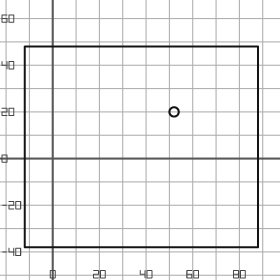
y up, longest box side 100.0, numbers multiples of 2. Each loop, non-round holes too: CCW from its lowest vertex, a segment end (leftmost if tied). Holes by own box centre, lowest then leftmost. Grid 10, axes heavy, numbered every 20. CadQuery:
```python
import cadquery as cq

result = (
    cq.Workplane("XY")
    .moveTo(-12.0, -38.0)
    .lineTo(88.0, -38.0)
    .lineTo(88.0, 48.0)
    .lineTo(-12.0, 48.0)
    .close()
    .moveTo(52.0, 20.0)
    .circle(2.0)
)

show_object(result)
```